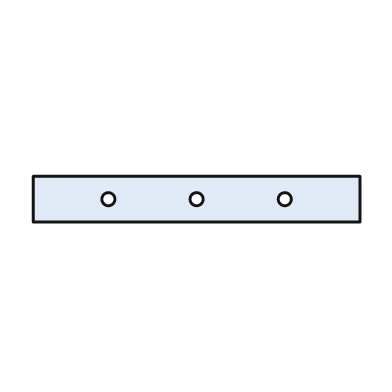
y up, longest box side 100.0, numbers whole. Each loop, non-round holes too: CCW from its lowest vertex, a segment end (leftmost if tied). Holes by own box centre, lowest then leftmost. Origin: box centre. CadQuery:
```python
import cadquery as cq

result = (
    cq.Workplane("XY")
    .moveTo(-50.0, -7.0)
    .lineTo(50.0, -7.0)
    .lineTo(50.0, 7.0)
    .lineTo(-50.0, 7.0)
    .close()
    .moveTo(-27.0, 0.0)
    .circle(2.0)
    .moveTo(0.0, 0.0)
    .circle(2.0)
    .moveTo(27.0, 0.0)
    .circle(2.0)
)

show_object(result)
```